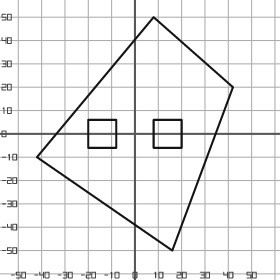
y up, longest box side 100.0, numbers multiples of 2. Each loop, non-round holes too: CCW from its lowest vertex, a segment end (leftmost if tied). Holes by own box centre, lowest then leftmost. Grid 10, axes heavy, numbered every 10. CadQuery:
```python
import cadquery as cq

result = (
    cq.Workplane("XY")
    .moveTo(16.0, -50.0)
    .lineTo(42.0, 20.0)
    .lineTo(8.0, 50.0)
    .lineTo(-42.0, -10.0)
    .close()
    .moveTo(-20.0, -6.0)
    .lineTo(-8.0, -6.0)
    .lineTo(-8.0, 6.0)
    .lineTo(-20.0, 6.0)
    .close()
    .moveTo(8.0, -6.0)
    .lineTo(20.0, -6.0)
    .lineTo(20.0, 6.0)
    .lineTo(8.0, 6.0)
    .close()
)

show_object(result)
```